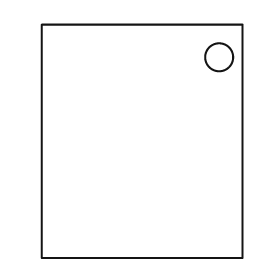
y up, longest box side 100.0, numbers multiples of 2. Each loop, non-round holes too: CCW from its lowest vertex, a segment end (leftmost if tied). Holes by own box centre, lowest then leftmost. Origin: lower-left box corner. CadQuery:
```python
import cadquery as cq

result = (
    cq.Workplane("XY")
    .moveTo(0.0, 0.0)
    .lineTo(86.0, 0.0)
    .lineTo(86.0, 100.0)
    .lineTo(0.0, 100.0)
    .close()
    .moveTo(76.0, 86.0)
    .circle(6.0)
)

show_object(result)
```